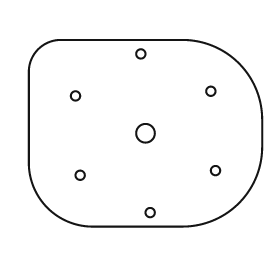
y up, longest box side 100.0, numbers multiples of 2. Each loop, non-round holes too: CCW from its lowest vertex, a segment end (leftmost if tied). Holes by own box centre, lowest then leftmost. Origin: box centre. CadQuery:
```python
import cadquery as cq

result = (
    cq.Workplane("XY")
    .moveTo(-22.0, -40.0)
    .lineTo(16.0, -40.0)
    .threePointArc((40.0, -30.0), (50.0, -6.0))
    .lineTo(50.0, 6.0)
    .threePointArc((40.0, 30.0), (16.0, 40.0))
    .lineTo(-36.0, 40.0)
    .threePointArc((-46.0, 36.0), (-50.0, 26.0))
    .lineTo(-50.0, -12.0)
    .threePointArc((-42.0, -32.0), (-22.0, -40.0))
    .close()
    .moveTo(2.0, -34.0)
    .circle(2.0)
    .moveTo(-28.0, -18.0)
    .circle(2.0)
    .moveTo(30.0, -16.0)
    .circle(2.0)
    .moveTo(0.0, 0.0)
    .circle(4.0)
    .moveTo(-30.0, 16.0)
    .circle(2.0)
    .moveTo(28.0, 18.0)
    .circle(2.0)
    .moveTo(-2.0, 34.0)
    .circle(2.0)
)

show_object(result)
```